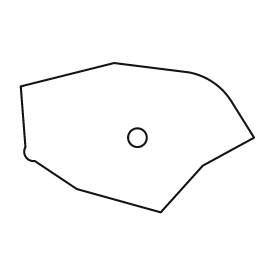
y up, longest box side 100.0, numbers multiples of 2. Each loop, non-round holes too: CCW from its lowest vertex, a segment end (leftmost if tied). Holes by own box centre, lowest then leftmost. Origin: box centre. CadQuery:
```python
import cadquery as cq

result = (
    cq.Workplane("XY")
    .moveTo(10.0, -32.0)
    .lineTo(28.0, -12.0)
    .lineTo(50.0, 0.0)
    .lineTo(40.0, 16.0)
    .threePointArc((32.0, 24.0), (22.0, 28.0))
    .lineTo(-10.0, 32.0)
    .lineTo(-50.0, 22.0)
    .lineTo(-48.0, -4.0)
    .threePointArc((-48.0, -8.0), (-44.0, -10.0))
    .lineTo(-26.0, -22.0)
    .close()
    .moveTo(0.0, 0.0)
    .circle(4.0)
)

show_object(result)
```